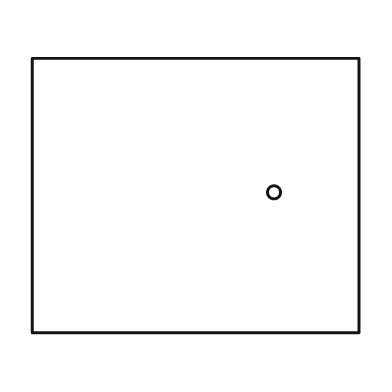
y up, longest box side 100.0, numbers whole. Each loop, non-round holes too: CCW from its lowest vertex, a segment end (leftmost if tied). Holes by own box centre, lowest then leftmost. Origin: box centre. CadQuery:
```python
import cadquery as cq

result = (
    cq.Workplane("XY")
    .moveTo(-50.0, -42.0)
    .lineTo(50.0, -42.0)
    .lineTo(50.0, 42.0)
    .lineTo(-50.0, 42.0)
    .close()
    .moveTo(24.0, 1.0)
    .circle(2.0)
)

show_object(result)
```